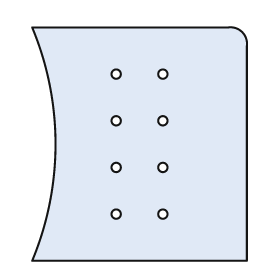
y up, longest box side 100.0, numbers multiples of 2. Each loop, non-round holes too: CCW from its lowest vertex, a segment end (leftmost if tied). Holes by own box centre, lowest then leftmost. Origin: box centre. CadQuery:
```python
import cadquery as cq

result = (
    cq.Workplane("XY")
    .moveTo(-46.0, -50.0)
    .lineTo(46.0, -50.0)
    .lineTo(46.0, 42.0)
    .threePointArc((44.0, 48.0), (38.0, 50.0))
    .lineTo(-46.0, 50.0)
    .threePointArc((-36.0, 0.0), (-46.0, -50.0))
    .close()
    .moveTo(-10.0, -30.0)
    .circle(2.0)
    .moveTo(10.0, -30.0)
    .circle(2.0)
    .moveTo(-10.0, -10.0)
    .circle(2.0)
    .moveTo(10.0, -10.0)
    .circle(2.0)
    .moveTo(-10.0, 10.0)
    .circle(2.0)
    .moveTo(10.0, 10.0)
    .circle(2.0)
    .moveTo(-10.0, 30.0)
    .circle(2.0)
    .moveTo(10.0, 30.0)
    .circle(2.0)
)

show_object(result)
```